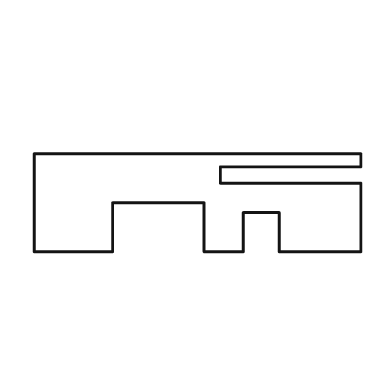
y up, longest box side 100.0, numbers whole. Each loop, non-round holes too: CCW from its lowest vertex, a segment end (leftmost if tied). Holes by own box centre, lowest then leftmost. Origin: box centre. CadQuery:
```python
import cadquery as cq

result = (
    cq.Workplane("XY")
    .moveTo(-50.0, -15.0)
    .lineTo(-26.0, -15.0)
    .lineTo(-26.0, 0.0)
    .lineTo(2.0, 0.0)
    .lineTo(2.0, -15.0)
    .lineTo(14.0, -15.0)
    .lineTo(14.0, -3.0)
    .lineTo(25.0, -3.0)
    .lineTo(25.0, -15.0)
    .lineTo(50.0, -15.0)
    .lineTo(50.0, 6.0)
    .lineTo(7.0, 6.0)
    .lineTo(7.0, 11.0)
    .lineTo(50.0, 11.0)
    .lineTo(50.0, 15.0)
    .lineTo(-50.0, 15.0)
    .close()
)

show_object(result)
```